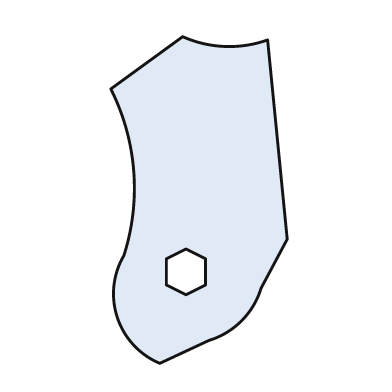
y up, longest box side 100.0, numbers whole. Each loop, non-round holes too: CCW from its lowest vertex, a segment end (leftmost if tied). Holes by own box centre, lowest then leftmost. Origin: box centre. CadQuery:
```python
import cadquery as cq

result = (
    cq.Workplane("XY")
    .moveTo(-12.0, -50.0)
    .lineTo(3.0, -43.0)
    .threePointArc((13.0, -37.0), (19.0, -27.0))
    .lineTo(27.0, -12.0)
    .lineTo(21.0, 49.0)
    .threePointArc((8.0, 47.0), (-5.0, 50.0))
    .lineTo(-27.0, 34.0)
    .threePointArc((-20.0, 9.0), (-23.0, -17.0))
    .threePointArc((-25.0, -36.0), (-12.0, -50.0))
    .close()
    .moveTo(-4.0, -29.0)
    .lineTo(2.0, -26.0)
    .lineTo(2.0, -18.0)
    .lineTo(-4.0, -15.0)
    .lineTo(-10.0, -18.0)
    .lineTo(-10.0, -26.0)
    .close()
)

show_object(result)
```